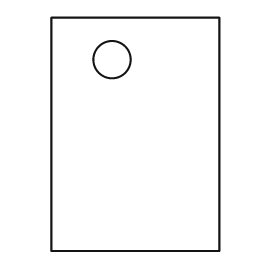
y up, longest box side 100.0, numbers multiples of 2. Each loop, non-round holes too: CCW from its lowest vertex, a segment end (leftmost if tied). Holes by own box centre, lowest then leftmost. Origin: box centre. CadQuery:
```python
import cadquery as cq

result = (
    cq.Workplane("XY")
    .moveTo(-36.0, -50.0)
    .lineTo(36.0, -50.0)
    .lineTo(36.0, 50.0)
    .lineTo(-36.0, 50.0)
    .close()
    .moveTo(-10.0, 32.0)
    .circle(8.0)
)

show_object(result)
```